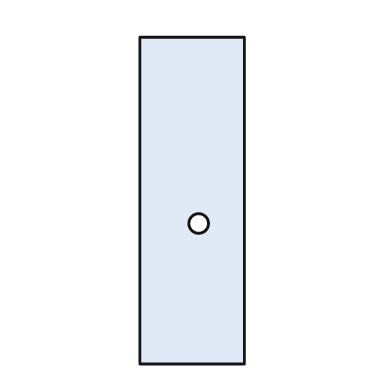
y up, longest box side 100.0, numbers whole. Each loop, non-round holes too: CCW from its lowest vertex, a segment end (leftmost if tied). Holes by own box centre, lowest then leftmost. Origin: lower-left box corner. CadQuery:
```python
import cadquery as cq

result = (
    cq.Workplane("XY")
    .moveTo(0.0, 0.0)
    .lineTo(32.0, 0.0)
    .lineTo(32.0, 100.0)
    .lineTo(0.0, 100.0)
    .close()
    .moveTo(18.0, 43.0)
    .circle(3.0)
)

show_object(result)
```